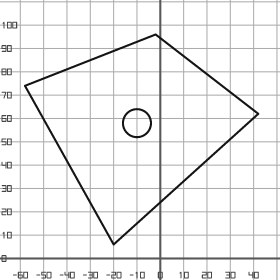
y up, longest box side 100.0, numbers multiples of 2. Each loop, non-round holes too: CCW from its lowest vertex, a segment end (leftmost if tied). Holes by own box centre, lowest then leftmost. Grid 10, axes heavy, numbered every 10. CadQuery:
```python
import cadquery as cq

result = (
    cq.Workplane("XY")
    .moveTo(-20.0, 6.0)
    .lineTo(42.0, 62.0)
    .lineTo(-2.0, 96.0)
    .lineTo(-58.0, 74.0)
    .close()
    .moveTo(-10.0, 58.0)
    .circle(6.0)
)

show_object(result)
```